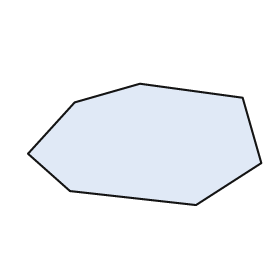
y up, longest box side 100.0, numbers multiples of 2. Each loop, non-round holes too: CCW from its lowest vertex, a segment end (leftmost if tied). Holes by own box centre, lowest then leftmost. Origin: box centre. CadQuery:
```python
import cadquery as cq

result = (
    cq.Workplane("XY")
    .moveTo(22.0, -26.0)
    .lineTo(50.0, -8.0)
    .lineTo(42.0, 20.0)
    .lineTo(-2.0, 26.0)
    .lineTo(-30.0, 18.0)
    .lineTo(-50.0, -4.0)
    .lineTo(-32.0, -20.0)
    .close()
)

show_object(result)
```